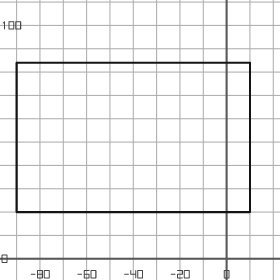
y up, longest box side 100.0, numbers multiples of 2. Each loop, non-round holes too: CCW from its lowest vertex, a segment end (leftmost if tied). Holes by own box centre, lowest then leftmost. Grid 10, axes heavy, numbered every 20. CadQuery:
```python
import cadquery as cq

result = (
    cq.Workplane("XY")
    .moveTo(-90.0, 20.0)
    .lineTo(10.0, 20.0)
    .lineTo(10.0, 84.0)
    .lineTo(-90.0, 84.0)
    .close()
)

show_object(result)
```